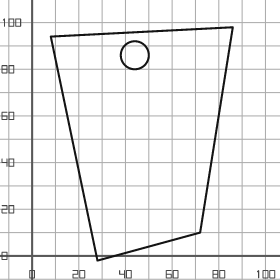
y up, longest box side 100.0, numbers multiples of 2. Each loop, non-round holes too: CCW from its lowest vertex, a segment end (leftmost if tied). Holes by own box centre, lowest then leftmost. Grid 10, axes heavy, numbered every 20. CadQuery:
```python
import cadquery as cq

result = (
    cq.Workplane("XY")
    .moveTo(28.0, -2.0)
    .lineTo(72.0, 10.0)
    .lineTo(86.0, 98.0)
    .lineTo(8.0, 94.0)
    .close()
    .moveTo(44.0, 86.0)
    .circle(6.0)
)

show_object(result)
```